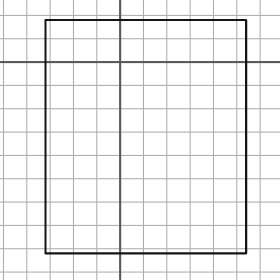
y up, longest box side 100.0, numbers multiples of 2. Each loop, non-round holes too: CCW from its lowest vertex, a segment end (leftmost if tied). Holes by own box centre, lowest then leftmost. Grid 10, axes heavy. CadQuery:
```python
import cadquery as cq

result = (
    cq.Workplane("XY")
    .moveTo(-32.0, -82.0)
    .lineTo(54.0, -82.0)
    .lineTo(54.0, 18.0)
    .lineTo(-32.0, 18.0)
    .close()
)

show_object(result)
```